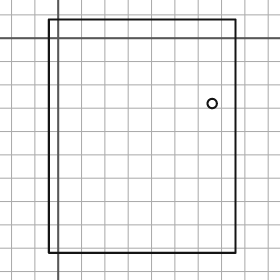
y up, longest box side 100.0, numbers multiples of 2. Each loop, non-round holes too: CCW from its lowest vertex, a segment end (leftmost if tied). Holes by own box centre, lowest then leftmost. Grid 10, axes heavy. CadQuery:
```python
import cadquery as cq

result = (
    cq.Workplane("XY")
    .moveTo(-4.0, -92.0)
    .lineTo(76.0, -92.0)
    .lineTo(76.0, 8.0)
    .lineTo(-4.0, 8.0)
    .close()
    .moveTo(66.0, -28.0)
    .circle(2.0)
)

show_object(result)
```